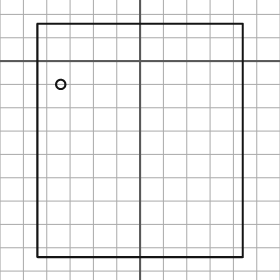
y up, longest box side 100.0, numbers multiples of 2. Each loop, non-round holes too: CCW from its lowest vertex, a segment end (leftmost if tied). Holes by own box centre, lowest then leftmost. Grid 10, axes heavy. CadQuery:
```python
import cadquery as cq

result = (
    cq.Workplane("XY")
    .moveTo(-44.0, -84.0)
    .lineTo(44.0, -84.0)
    .lineTo(44.0, 16.0)
    .lineTo(-44.0, 16.0)
    .close()
    .moveTo(-34.0, -10.0)
    .circle(2.0)
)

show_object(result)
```